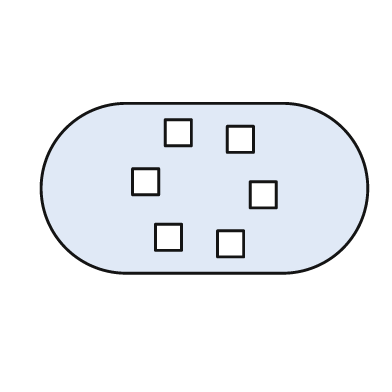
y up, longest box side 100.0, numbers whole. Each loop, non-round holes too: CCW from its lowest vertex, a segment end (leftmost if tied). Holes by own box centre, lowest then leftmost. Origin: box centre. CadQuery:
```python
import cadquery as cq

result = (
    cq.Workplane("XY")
    .moveTo(-24.0, -26.0)
    .lineTo(24.0, -26.0)
    .threePointArc((50.0, 0.0), (24.0, 26.0))
    .lineTo(-24.0, 26.0)
    .threePointArc((-50.0, 0.0), (-24.0, -26.0))
    .close()
    .moveTo(4.0, -21.0)
    .lineTo(12.0, -21.0)
    .lineTo(12.0, -13.0)
    .lineTo(4.0, -13.0)
    .close()
    .moveTo(-15.0, -19.0)
    .lineTo(-7.0, -19.0)
    .lineTo(-7.0, -11.0)
    .lineTo(-15.0, -11.0)
    .close()
    .moveTo(14.0, -6.0)
    .lineTo(22.0, -6.0)
    .lineTo(22.0, 2.0)
    .lineTo(14.0, 2.0)
    .close()
    .moveTo(-22.0, -2.0)
    .lineTo(-14.0, -2.0)
    .lineTo(-14.0, 6.0)
    .lineTo(-22.0, 6.0)
    .close()
    .moveTo(7.0, 11.0)
    .lineTo(15.0, 11.0)
    .lineTo(15.0, 19.0)
    .lineTo(7.0, 19.0)
    .close()
    .moveTo(-12.0, 13.0)
    .lineTo(-4.0, 13.0)
    .lineTo(-4.0, 21.0)
    .lineTo(-12.0, 21.0)
    .close()
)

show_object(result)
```